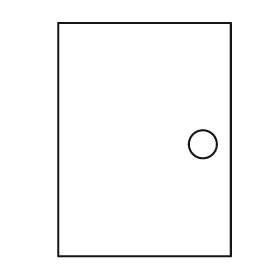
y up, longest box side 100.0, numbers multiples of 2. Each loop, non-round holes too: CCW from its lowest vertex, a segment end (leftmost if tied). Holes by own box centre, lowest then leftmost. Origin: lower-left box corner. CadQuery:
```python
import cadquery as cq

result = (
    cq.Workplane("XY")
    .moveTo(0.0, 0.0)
    .lineTo(74.0, 0.0)
    .lineTo(74.0, 100.0)
    .lineTo(0.0, 100.0)
    .close()
    .moveTo(62.0, 48.0)
    .circle(6.0)
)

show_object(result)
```